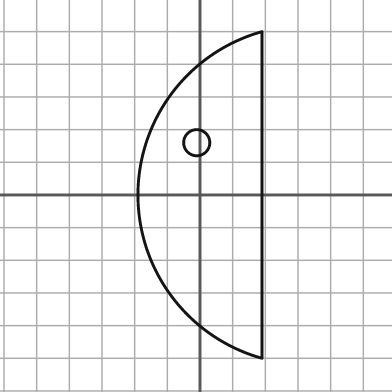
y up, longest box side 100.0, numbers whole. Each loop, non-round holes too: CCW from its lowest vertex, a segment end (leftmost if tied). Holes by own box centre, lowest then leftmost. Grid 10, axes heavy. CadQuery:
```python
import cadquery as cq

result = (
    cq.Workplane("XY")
    .moveTo(19.0, -50.0)
    .lineTo(19.0, 50.0)
    .threePointArc((-19.0, 0.0), (19.0, -50.0))
    .close()
    .moveTo(-1.0, 16.0)
    .circle(4.0)
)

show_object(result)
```